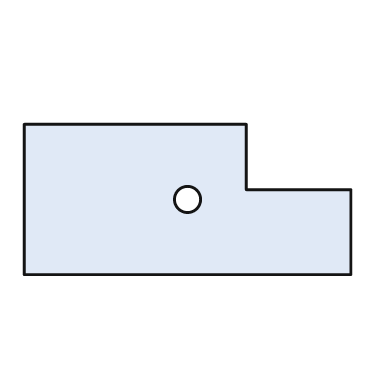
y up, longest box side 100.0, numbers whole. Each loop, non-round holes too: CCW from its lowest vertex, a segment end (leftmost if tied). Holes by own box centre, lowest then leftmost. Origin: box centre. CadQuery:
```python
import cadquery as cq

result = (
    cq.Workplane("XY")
    .moveTo(-50.0, -23.0)
    .lineTo(50.0, -23.0)
    .lineTo(50.0, 3.0)
    .lineTo(18.0, 3.0)
    .lineTo(18.0, 23.0)
    .lineTo(-50.0, 23.0)
    .close()
    .moveTo(0.0, 0.0)
    .circle(4.0)
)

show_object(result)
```